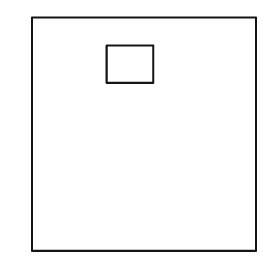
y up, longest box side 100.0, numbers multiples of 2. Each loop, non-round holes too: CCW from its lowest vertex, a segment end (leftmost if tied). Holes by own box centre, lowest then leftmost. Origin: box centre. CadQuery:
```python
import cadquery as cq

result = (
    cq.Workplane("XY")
    .moveTo(-48.0, -50.0)
    .lineTo(48.0, -50.0)
    .lineTo(48.0, 50.0)
    .lineTo(-48.0, 50.0)
    .close()
    .moveTo(-16.0, 22.0)
    .lineTo(4.0, 22.0)
    .lineTo(4.0, 38.0)
    .lineTo(-16.0, 38.0)
    .close()
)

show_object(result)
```